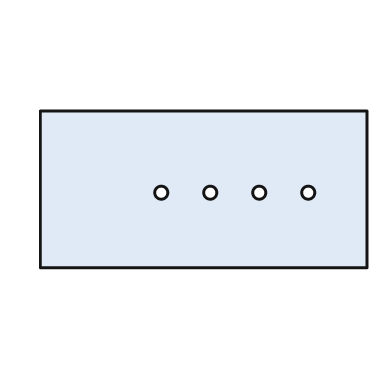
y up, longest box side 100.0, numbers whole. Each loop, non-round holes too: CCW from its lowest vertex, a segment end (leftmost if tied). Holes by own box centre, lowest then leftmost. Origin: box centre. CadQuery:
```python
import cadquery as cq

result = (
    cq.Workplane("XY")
    .moveTo(-50.0, -24.0)
    .lineTo(50.0, -24.0)
    .lineTo(50.0, 24.0)
    .lineTo(-50.0, 24.0)
    .close()
    .moveTo(-13.0, -1.0)
    .circle(2.0)
    .moveTo(2.0, -1.0)
    .circle(2.0)
    .moveTo(17.0, -1.0)
    .circle(2.0)
    .moveTo(32.0, -1.0)
    .circle(2.0)
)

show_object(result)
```